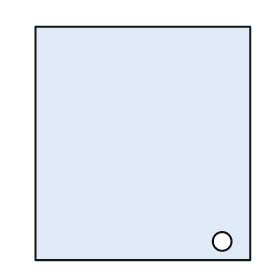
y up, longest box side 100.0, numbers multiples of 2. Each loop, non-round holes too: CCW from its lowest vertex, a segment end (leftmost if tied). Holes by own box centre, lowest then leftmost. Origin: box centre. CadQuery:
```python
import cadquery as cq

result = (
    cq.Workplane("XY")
    .moveTo(-46.0, -50.0)
    .lineTo(46.0, -50.0)
    .lineTo(46.0, 50.0)
    .lineTo(-46.0, 50.0)
    .close()
    .moveTo(34.0, -42.0)
    .circle(4.0)
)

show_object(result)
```